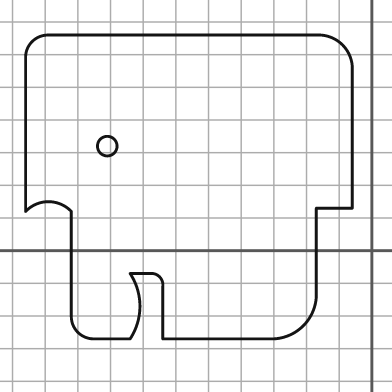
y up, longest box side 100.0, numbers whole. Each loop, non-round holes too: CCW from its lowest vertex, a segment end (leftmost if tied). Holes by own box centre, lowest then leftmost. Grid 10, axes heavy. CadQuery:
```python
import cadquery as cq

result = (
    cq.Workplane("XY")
    .moveTo(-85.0, -27.0)
    .lineTo(-74.0, -27.0)
    .threePointArc((-71.0, -17.0), (-74.0, -7.0))
    .lineTo(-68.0, -7.0)
    .threePointArc((-65.0, -8.0), (-64.0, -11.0))
    .lineTo(-64.0, -27.0)
    .lineTo(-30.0, -27.0)
    .threePointArc((-21.0, -23.0), (-17.0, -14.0))
    .lineTo(-17.0, 13.0)
    .lineTo(-6.0, 13.0)
    .lineTo(-6.0, 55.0)
    .threePointArc((-9.0, 63.0), (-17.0, 66.0))
    .lineTo(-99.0, 66.0)
    .threePointArc((-104.0, 64.0), (-106.0, 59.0))
    .lineTo(-106.0, 12.0)
    .threePointArc((-99.0, 15.0), (-92.0, 12.0))
    .lineTo(-92.0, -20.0)
    .threePointArc((-90.0, -25.0), (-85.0, -27.0))
    .close()
    .moveTo(-81.0, 32.0)
    .circle(3.0)
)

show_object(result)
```